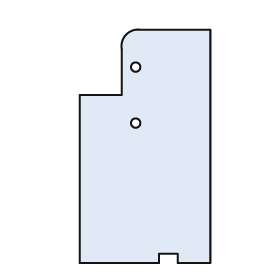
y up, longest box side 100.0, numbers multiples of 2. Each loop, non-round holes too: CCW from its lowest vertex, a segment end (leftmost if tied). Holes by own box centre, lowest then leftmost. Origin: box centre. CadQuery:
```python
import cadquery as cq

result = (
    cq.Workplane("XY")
    .moveTo(-28.0, -50.0)
    .lineTo(6.0, -50.0)
    .lineTo(6.0, -46.0)
    .lineTo(14.0, -46.0)
    .lineTo(14.0, -50.0)
    .lineTo(28.0, -50.0)
    .lineTo(28.0, 50.0)
    .lineTo(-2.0, 50.0)
    .threePointArc((-8.0, 48.0), (-10.0, 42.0))
    .lineTo(-10.0, 22.0)
    .lineTo(-28.0, 22.0)
    .close()
    .moveTo(-4.0, 10.0)
    .circle(2.0)
    .moveTo(-4.0, 34.0)
    .circle(2.0)
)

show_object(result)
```